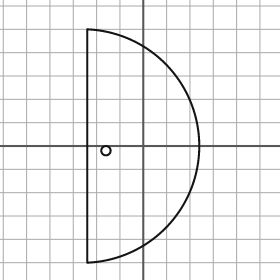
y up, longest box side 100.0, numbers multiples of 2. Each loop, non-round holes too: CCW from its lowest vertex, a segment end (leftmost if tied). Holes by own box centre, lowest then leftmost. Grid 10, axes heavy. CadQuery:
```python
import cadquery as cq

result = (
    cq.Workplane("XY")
    .moveTo(-24.0, -50.0)
    .threePointArc((24.0, 0.0), (-24.0, 50.0))
    .close()
    .moveTo(-16.0, -2.0)
    .circle(2.0)
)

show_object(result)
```